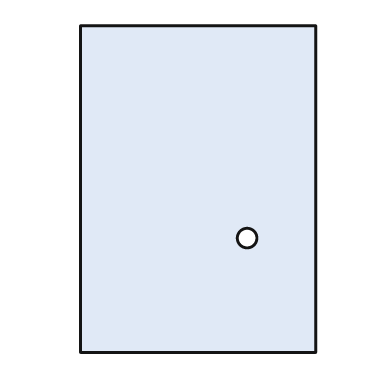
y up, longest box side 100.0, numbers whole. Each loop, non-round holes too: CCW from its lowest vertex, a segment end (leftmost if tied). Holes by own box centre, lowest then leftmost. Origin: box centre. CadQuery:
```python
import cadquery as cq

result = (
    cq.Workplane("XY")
    .moveTo(-36.0, -50.0)
    .lineTo(36.0, -50.0)
    .lineTo(36.0, 50.0)
    .lineTo(-36.0, 50.0)
    .close()
    .moveTo(15.0, -15.0)
    .circle(3.0)
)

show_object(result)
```